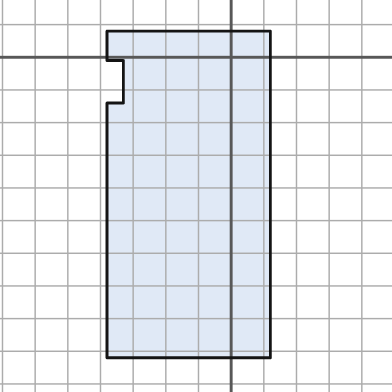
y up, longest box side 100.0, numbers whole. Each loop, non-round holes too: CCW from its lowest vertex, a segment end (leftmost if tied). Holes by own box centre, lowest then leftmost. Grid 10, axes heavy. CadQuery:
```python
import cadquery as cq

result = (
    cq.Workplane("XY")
    .moveTo(-38.0, -92.0)
    .lineTo(12.0, -92.0)
    .lineTo(12.0, 8.0)
    .lineTo(-38.0, 8.0)
    .lineTo(-38.0, -1.0)
    .lineTo(-33.0, -1.0)
    .lineTo(-33.0, -14.0)
    .lineTo(-38.0, -14.0)
    .close()
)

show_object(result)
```